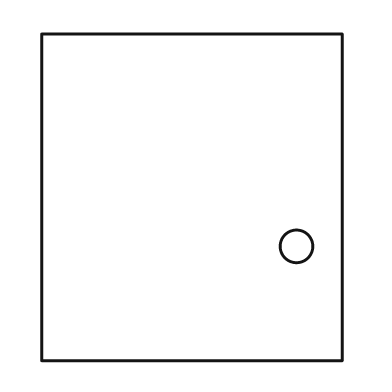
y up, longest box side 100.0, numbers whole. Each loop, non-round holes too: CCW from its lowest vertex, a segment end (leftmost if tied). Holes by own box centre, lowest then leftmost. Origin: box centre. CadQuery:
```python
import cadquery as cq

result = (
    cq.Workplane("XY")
    .moveTo(-46.0, -50.0)
    .lineTo(46.0, -50.0)
    .lineTo(46.0, 50.0)
    .lineTo(-46.0, 50.0)
    .close()
    .moveTo(32.0, -15.0)
    .circle(5.0)
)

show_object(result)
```